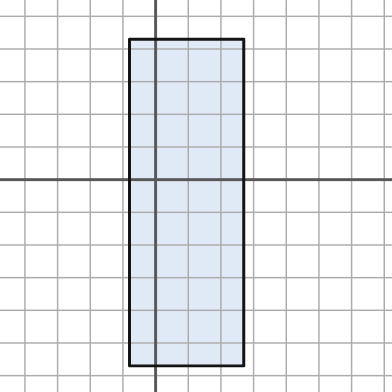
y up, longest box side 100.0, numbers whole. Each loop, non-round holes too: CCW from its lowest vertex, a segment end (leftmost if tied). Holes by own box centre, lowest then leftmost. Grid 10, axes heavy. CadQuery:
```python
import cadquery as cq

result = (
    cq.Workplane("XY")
    .moveTo(-8.0, -57.0)
    .lineTo(27.0, -57.0)
    .lineTo(27.0, 43.0)
    .lineTo(-8.0, 43.0)
    .close()
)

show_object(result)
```